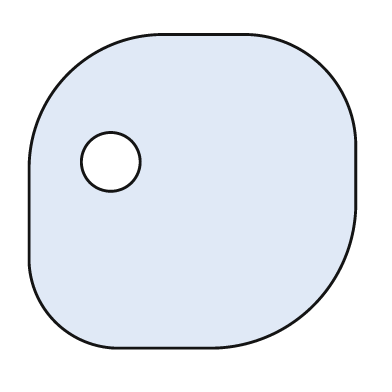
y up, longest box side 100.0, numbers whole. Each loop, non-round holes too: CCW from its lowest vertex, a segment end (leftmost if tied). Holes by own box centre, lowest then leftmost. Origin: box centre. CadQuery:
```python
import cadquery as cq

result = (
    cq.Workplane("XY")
    .moveTo(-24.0, -48.0)
    .lineTo(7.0, -48.0)
    .threePointArc((37.0, -35.0), (50.0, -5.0))
    .lineTo(50.0, 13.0)
    .threePointArc((40.0, 38.0), (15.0, 48.0))
    .lineTo(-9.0, 48.0)
    .threePointArc((-38.0, 36.0), (-50.0, 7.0))
    .lineTo(-50.0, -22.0)
    .threePointArc((-42.0, -40.0), (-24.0, -48.0))
    .close()
    .moveTo(-25.0, 9.0)
    .circle(9.0)
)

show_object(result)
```